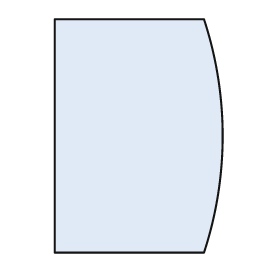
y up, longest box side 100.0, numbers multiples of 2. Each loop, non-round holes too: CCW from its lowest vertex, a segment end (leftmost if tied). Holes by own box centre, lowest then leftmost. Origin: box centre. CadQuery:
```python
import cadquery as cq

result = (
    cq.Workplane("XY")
    .moveTo(-36.0, -50.0)
    .lineTo(28.0, -50.0)
    .threePointArc((36.0, 0.0), (28.0, 50.0))
    .lineTo(-36.0, 50.0)
    .close()
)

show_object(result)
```